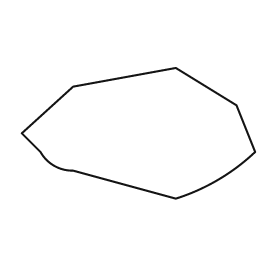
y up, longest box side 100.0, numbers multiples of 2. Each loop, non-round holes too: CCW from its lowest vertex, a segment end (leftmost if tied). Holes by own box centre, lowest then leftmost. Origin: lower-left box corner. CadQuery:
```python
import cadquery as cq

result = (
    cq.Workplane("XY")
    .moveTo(66.0, 0.0)
    .threePointArc((84.0, 8.0), (100.0, 20.0))
    .lineTo(92.0, 40.0)
    .lineTo(66.0, 56.0)
    .lineTo(22.0, 48.0)
    .lineTo(0.0, 28.0)
    .lineTo(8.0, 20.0)
    .threePointArc((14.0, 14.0), (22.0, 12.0))
    .close()
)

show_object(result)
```